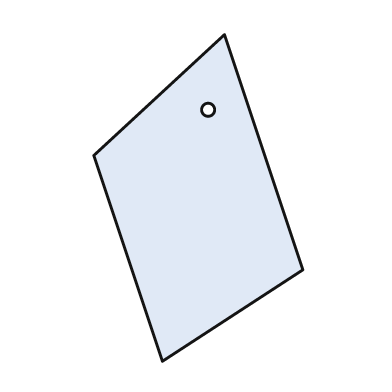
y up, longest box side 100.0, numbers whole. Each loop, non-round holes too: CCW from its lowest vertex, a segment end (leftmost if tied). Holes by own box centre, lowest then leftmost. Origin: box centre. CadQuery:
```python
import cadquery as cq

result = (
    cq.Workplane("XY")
    .moveTo(-11.0, -50.0)
    .lineTo(32.0, -22.0)
    .lineTo(8.0, 50.0)
    .lineTo(-32.0, 13.0)
    .close()
    .moveTo(3.0, 27.0)
    .circle(2.0)
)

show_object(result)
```